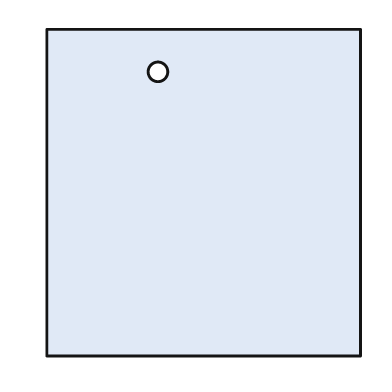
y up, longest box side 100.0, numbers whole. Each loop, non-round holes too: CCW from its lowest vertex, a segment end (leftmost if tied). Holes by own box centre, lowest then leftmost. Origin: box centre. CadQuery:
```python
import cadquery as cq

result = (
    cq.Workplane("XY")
    .moveTo(-48.0, -50.0)
    .lineTo(48.0, -50.0)
    .lineTo(48.0, 50.0)
    .lineTo(-48.0, 50.0)
    .close()
    .moveTo(-14.0, 37.0)
    .circle(3.0)
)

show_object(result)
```